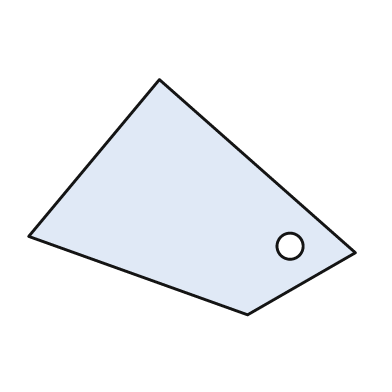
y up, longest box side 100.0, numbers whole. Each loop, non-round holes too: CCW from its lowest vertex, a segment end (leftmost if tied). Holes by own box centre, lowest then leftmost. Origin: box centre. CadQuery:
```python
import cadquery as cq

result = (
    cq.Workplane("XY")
    .moveTo(17.0, -36.0)
    .lineTo(50.0, -17.0)
    .lineTo(-10.0, 36.0)
    .lineTo(-50.0, -12.0)
    .close()
    .moveTo(30.0, -15.0)
    .circle(4.0)
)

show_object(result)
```